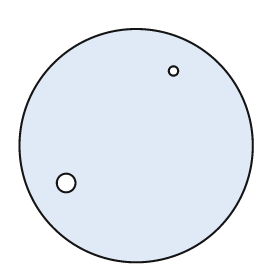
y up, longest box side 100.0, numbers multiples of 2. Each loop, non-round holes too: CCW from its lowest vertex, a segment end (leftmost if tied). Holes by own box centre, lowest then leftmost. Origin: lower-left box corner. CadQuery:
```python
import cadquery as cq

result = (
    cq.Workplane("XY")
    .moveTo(50.0, 50.0)
    .circle(50.0)
    .moveTo(20.0, 34.0)
    .circle(4.0)
    .moveTo(66.0, 82.0)
    .circle(2.0)
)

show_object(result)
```